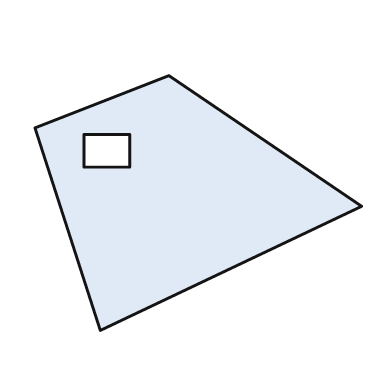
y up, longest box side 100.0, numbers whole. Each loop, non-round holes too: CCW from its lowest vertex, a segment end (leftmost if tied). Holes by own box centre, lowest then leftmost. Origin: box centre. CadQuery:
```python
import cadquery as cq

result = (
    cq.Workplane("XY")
    .moveTo(-30.0, -39.0)
    .lineTo(50.0, -1.0)
    .lineTo(-9.0, 39.0)
    .lineTo(-50.0, 23.0)
    .close()
    .moveTo(-35.0, 11.0)
    .lineTo(-21.0, 11.0)
    .lineTo(-21.0, 21.0)
    .lineTo(-35.0, 21.0)
    .close()
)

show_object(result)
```